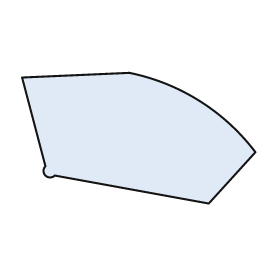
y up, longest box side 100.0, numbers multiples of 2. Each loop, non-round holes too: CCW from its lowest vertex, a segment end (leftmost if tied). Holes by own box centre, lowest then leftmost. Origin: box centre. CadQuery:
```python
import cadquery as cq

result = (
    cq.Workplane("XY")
    .moveTo(30.0, -28.0)
    .lineTo(50.0, -6.0)
    .threePointArc((26.0, 16.0), (-4.0, 28.0))
    .lineTo(-50.0, 26.0)
    .lineTo(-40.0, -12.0)
    .threePointArc((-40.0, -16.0), (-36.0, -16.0))
    .close()
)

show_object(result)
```